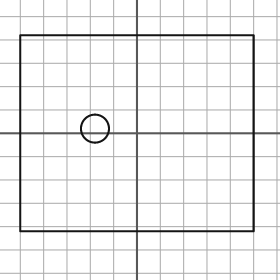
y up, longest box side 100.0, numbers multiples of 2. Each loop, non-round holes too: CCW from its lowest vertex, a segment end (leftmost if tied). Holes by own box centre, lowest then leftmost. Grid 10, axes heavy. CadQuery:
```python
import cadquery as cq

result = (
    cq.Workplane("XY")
    .moveTo(-50.0, -42.0)
    .lineTo(50.0, -42.0)
    .lineTo(50.0, 42.0)
    .lineTo(-50.0, 42.0)
    .close()
    .moveTo(-18.0, 2.0)
    .circle(6.0)
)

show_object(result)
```